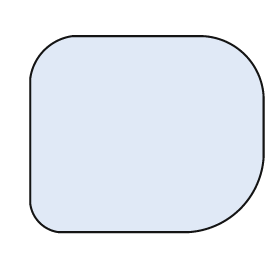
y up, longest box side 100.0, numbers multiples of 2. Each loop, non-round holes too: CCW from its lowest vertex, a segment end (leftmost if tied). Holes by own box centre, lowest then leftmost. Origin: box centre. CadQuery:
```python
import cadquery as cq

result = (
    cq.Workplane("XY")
    .moveTo(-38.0, -42.0)
    .lineTo(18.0, -42.0)
    .threePointArc((40.0, -32.0), (50.0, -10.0))
    .lineTo(50.0, 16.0)
    .threePointArc((42.0, 34.0), (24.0, 42.0))
    .lineTo(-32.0, 42.0)
    .threePointArc((-44.0, 36.0), (-50.0, 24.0))
    .lineTo(-50.0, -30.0)
    .threePointArc((-46.0, -38.0), (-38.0, -42.0))
    .close()
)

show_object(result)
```